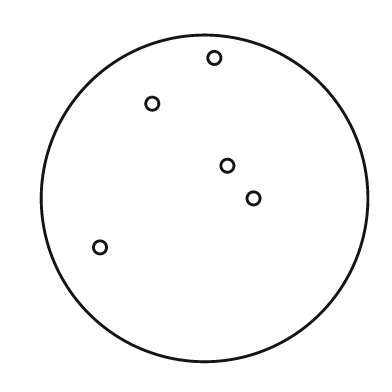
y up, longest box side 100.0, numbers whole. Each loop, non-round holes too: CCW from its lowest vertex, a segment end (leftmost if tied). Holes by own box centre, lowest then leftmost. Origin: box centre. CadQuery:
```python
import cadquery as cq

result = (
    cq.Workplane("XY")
    .moveTo(0.0, 0.0)
    .circle(50.0)
    .moveTo(-32.0, -15.0)
    .circle(2.0)
    .moveTo(15.0, 0.0)
    .circle(2.0)
    .moveTo(7.0, 10.0)
    .circle(2.0)
    .moveTo(-16.0, 29.0)
    .circle(2.0)
    .moveTo(3.0, 43.0)
    .circle(2.0)
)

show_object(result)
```